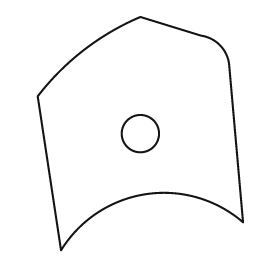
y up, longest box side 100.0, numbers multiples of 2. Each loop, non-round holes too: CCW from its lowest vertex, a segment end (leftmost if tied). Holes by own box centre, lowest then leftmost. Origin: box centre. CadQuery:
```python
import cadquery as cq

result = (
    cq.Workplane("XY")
    .moveTo(-34.0, -50.0)
    .threePointArc((2.0, -26.0), (44.0, -38.0))
    .lineTo(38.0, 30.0)
    .threePointArc((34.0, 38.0), (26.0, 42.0))
    .lineTo(0.0, 50.0)
    .threePointArc((-24.0, 36.0), (-44.0, 16.0))
    .close()
    .moveTo(0.0, 0.0)
    .circle(8.0)
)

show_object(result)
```